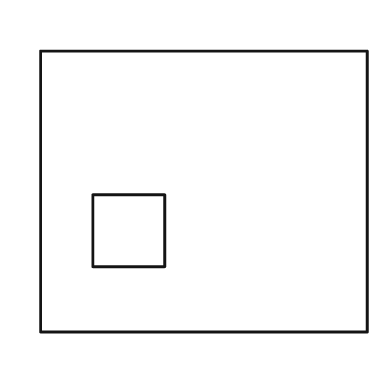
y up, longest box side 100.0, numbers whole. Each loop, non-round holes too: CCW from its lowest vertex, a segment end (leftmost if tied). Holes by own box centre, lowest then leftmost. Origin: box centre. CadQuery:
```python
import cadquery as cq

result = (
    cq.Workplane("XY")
    .moveTo(-50.0, -43.0)
    .lineTo(50.0, -43.0)
    .lineTo(50.0, 43.0)
    .lineTo(-50.0, 43.0)
    .close()
    .moveTo(-34.0, -23.0)
    .lineTo(-12.0, -23.0)
    .lineTo(-12.0, -1.0)
    .lineTo(-34.0, -1.0)
    .close()
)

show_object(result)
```